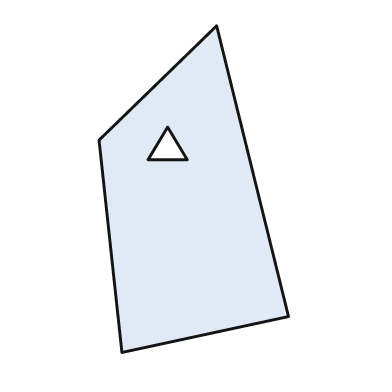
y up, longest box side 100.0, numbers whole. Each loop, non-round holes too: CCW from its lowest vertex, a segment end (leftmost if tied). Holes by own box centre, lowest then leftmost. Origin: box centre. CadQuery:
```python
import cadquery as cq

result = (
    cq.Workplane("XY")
    .moveTo(-22.0, -50.0)
    .lineTo(29.0, -39.0)
    .lineTo(7.0, 50.0)
    .lineTo(-29.0, 15.0)
    .close()
    .moveTo(-14.0, 9.0)
    .lineTo(-2.0, 9.0)
    .lineTo(-8.0, 19.0)
    .close()
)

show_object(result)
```